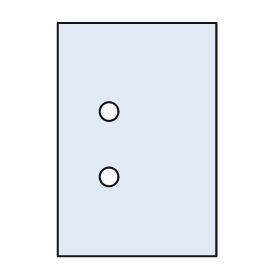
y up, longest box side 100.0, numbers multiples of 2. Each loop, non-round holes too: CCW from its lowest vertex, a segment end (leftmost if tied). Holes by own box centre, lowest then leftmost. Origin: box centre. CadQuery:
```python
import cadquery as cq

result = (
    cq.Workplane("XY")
    .moveTo(-34.0, -50.0)
    .lineTo(34.0, -50.0)
    .lineTo(34.0, 50.0)
    .lineTo(-34.0, 50.0)
    .close()
    .moveTo(-12.0, -16.0)
    .circle(4.0)
    .moveTo(-12.0, 12.0)
    .circle(4.0)
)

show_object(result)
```